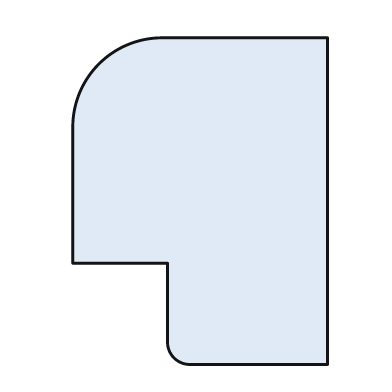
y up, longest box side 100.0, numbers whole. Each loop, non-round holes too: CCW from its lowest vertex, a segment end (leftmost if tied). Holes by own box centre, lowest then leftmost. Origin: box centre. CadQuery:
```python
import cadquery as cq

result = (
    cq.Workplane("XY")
    .moveTo(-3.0, -50.0)
    .lineTo(39.0, -50.0)
    .lineTo(39.0, 50.0)
    .lineTo(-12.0, 50.0)
    .threePointArc((-31.0, 42.0), (-39.0, 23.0))
    .lineTo(-39.0, -19.0)
    .lineTo(-10.0, -19.0)
    .lineTo(-10.0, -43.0)
    .threePointArc((-8.0, -48.0), (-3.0, -50.0))
    .close()
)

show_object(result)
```